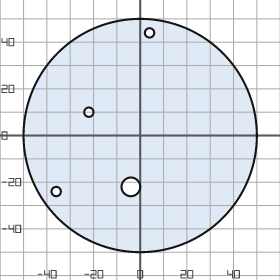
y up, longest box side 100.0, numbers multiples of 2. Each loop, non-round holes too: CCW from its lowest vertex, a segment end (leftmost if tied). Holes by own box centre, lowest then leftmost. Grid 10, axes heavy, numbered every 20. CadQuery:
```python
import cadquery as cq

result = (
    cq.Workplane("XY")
    .moveTo(0.0, 0.0)
    .circle(50.0)
    .moveTo(-36.0, -24.0)
    .circle(2.0)
    .moveTo(-4.0, -22.0)
    .circle(4.0)
    .moveTo(-22.0, 10.0)
    .circle(2.0)
    .moveTo(4.0, 44.0)
    .circle(2.0)
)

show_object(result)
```